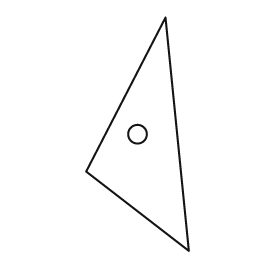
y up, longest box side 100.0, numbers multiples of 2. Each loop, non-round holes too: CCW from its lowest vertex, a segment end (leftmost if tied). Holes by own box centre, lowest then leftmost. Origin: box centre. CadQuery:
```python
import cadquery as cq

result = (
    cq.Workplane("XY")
    .moveTo(22.0, -50.0)
    .lineTo(12.0, 50.0)
    .lineTo(-22.0, -16.0)
    .close()
    .moveTo(0.0, 0.0)
    .circle(4.0)
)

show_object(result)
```